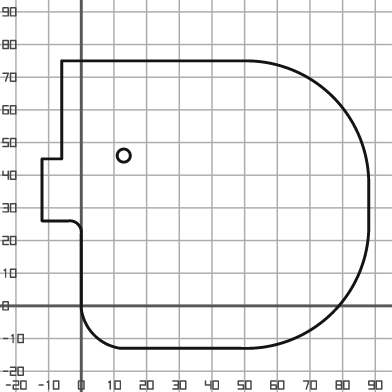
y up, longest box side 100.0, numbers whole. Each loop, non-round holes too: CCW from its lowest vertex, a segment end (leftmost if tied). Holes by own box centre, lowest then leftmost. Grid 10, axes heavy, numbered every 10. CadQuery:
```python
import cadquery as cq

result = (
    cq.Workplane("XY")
    .moveTo(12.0, -13.0)
    .lineTo(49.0, -13.0)
    .threePointArc((77.0, -2.0), (88.0, 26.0))
    .lineTo(88.0, 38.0)
    .threePointArc((77.0, 64.0), (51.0, 75.0))
    .lineTo(-6.0, 75.0)
    .lineTo(-6.0, 45.0)
    .lineTo(-12.0, 45.0)
    .lineTo(-12.0, 26.0)
    .lineTo(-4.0, 26.0)
    .threePointArc((-1.0, 25.0), (0.0, 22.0))
    .lineTo(0.0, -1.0)
    .threePointArc((4.0, -9.0), (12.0, -13.0))
    .close()
    .moveTo(13.0, 46.0)
    .circle(2.0)
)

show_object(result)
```